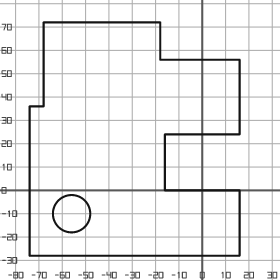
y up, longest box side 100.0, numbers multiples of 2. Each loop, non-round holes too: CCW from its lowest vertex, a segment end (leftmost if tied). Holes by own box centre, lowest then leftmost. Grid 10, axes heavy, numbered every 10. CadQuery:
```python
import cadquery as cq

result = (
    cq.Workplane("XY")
    .moveTo(-74.0, -28.0)
    .lineTo(16.0, -28.0)
    .lineTo(16.0, 0.0)
    .lineTo(-16.0, 0.0)
    .lineTo(-16.0, 24.0)
    .lineTo(16.0, 24.0)
    .lineTo(16.0, 56.0)
    .lineTo(-18.0, 56.0)
    .lineTo(-18.0, 72.0)
    .lineTo(-68.0, 72.0)
    .lineTo(-68.0, 36.0)
    .lineTo(-74.0, 36.0)
    .close()
    .moveTo(-56.0, -10.0)
    .circle(8.0)
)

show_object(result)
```